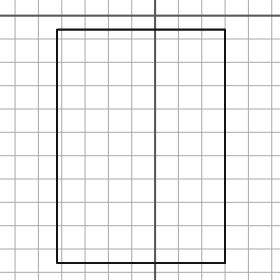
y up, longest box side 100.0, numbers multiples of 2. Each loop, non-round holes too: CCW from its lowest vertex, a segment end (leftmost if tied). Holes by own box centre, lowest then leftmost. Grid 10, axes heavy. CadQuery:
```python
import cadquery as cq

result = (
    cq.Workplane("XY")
    .moveTo(-42.0, -106.0)
    .lineTo(30.0, -106.0)
    .lineTo(30.0, -6.0)
    .lineTo(-42.0, -6.0)
    .close()
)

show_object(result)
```